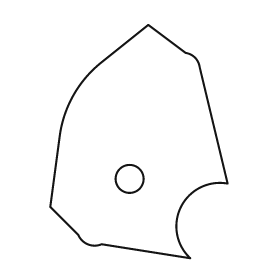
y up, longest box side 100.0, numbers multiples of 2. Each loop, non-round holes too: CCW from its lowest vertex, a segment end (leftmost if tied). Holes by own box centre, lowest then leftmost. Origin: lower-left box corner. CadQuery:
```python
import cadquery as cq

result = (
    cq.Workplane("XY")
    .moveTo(60.0, 0.0)
    .threePointArc((56.0, 22.0), (76.0, 32.0))
    .lineTo(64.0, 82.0)
    .threePointArc((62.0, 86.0), (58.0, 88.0))
    .lineTo(42.0, 100.0)
    .lineTo(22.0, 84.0)
    .threePointArc((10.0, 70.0), (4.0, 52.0))
    .lineTo(0.0, 22.0)
    .lineTo(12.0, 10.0)
    .threePointArc((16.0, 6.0), (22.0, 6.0))
    .close()
    .moveTo(34.0, 34.0)
    .circle(6.0)
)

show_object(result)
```